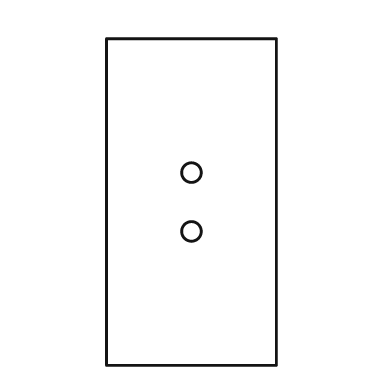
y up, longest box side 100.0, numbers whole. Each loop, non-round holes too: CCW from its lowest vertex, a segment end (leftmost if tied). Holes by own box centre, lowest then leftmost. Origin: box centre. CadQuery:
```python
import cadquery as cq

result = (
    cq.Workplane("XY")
    .moveTo(-26.0, -50.0)
    .lineTo(26.0, -50.0)
    .lineTo(26.0, 50.0)
    .lineTo(-26.0, 50.0)
    .close()
    .moveTo(0.0, -9.0)
    .circle(3.0)
    .moveTo(0.0, 9.0)
    .circle(3.0)
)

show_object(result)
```